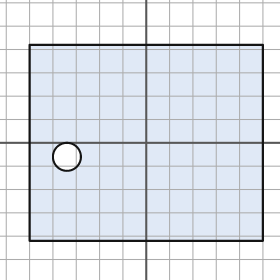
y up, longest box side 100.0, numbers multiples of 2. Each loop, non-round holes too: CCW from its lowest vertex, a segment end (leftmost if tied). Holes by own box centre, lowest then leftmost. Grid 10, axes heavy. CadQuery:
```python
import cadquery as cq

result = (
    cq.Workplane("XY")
    .moveTo(-50.0, -42.0)
    .lineTo(50.0, -42.0)
    .lineTo(50.0, 42.0)
    .lineTo(-50.0, 42.0)
    .close()
    .moveTo(-34.0, -6.0)
    .circle(6.0)
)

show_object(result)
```